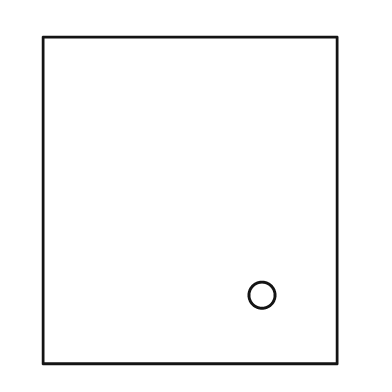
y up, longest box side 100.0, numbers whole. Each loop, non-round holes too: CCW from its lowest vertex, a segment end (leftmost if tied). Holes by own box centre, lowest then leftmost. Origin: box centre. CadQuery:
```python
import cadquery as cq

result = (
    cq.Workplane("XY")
    .moveTo(-45.0, -50.0)
    .lineTo(45.0, -50.0)
    .lineTo(45.0, 50.0)
    .lineTo(-45.0, 50.0)
    .close()
    .moveTo(22.0, -29.0)
    .circle(4.0)
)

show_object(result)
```